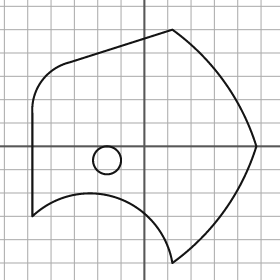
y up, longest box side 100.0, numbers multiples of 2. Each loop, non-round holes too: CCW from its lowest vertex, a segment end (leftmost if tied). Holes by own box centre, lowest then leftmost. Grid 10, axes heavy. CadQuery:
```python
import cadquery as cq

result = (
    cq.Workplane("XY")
    .moveTo(12.0, -50.0)
    .threePointArc((34.0, -28.0), (48.0, 0.0))
    .threePointArc((34.0, 28.0), (12.0, 50.0))
    .lineTo(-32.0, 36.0)
    .threePointArc((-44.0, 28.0), (-48.0, 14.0))
    .lineTo(-48.0, -30.0)
    .threePointArc((-12.0, -22.0), (12.0, -50.0))
    .close()
    .moveTo(-16.0, -6.0)
    .circle(6.0)
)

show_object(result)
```